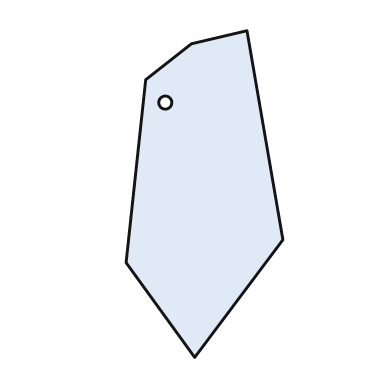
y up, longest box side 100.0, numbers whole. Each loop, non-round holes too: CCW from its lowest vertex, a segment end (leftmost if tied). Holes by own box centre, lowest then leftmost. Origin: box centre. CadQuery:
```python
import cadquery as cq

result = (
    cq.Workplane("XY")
    .moveTo(-3.0, -50.0)
    .lineTo(24.0, -14.0)
    .lineTo(13.0, 50.0)
    .lineTo(-4.0, 46.0)
    .lineTo(-18.0, 35.0)
    .lineTo(-24.0, -21.0)
    .close()
    .moveTo(-12.0, 28.0)
    .circle(2.0)
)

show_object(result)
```